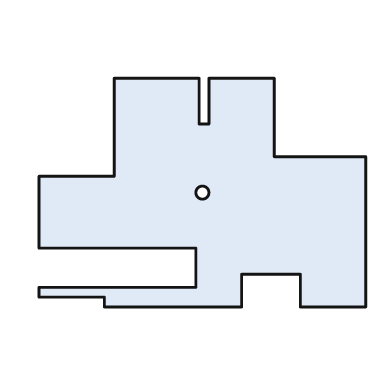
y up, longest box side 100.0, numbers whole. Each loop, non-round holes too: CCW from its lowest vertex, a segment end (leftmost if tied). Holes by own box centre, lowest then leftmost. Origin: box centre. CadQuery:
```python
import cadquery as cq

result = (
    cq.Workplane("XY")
    .moveTo(-30.0, -35.0)
    .lineTo(12.0, -35.0)
    .lineTo(12.0, -25.0)
    .lineTo(30.0, -25.0)
    .lineTo(30.0, -35.0)
    .lineTo(50.0, -35.0)
    .lineTo(50.0, 11.0)
    .lineTo(22.0, 11.0)
    .lineTo(22.0, 35.0)
    .lineTo(2.0, 35.0)
    .lineTo(2.0, 21.0)
    .lineTo(-1.0, 21.0)
    .lineTo(-1.0, 35.0)
    .lineTo(-27.0, 35.0)
    .lineTo(-27.0, 5.0)
    .lineTo(-50.0, 5.0)
    .lineTo(-50.0, -17.0)
    .lineTo(-2.0, -17.0)
    .lineTo(-2.0, -29.0)
    .lineTo(-50.0, -29.0)
    .lineTo(-50.0, -32.0)
    .lineTo(-30.0, -32.0)
    .close()
    .moveTo(0.0, 0.0)
    .circle(2.0)
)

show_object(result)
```